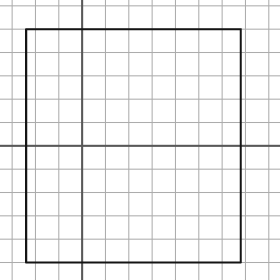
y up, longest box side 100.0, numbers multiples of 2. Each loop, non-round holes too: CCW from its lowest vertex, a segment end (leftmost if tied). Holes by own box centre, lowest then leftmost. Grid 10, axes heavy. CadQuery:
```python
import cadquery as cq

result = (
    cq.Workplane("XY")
    .moveTo(-24.0, -50.0)
    .lineTo(68.0, -50.0)
    .lineTo(68.0, 50.0)
    .lineTo(-24.0, 50.0)
    .close()
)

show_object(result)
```